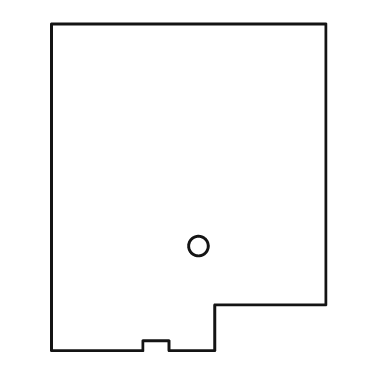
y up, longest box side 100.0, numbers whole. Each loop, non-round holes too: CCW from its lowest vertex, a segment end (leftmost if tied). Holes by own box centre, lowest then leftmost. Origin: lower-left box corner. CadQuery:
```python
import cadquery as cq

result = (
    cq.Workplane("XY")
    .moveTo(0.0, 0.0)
    .lineTo(28.0, 0.0)
    .lineTo(28.0, 3.0)
    .lineTo(36.0, 3.0)
    .lineTo(36.0, 0.0)
    .lineTo(50.0, 0.0)
    .lineTo(50.0, 14.0)
    .lineTo(84.0, 14.0)
    .lineTo(84.0, 100.0)
    .lineTo(0.0, 100.0)
    .close()
    .moveTo(45.0, 32.0)
    .circle(3.0)
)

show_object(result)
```